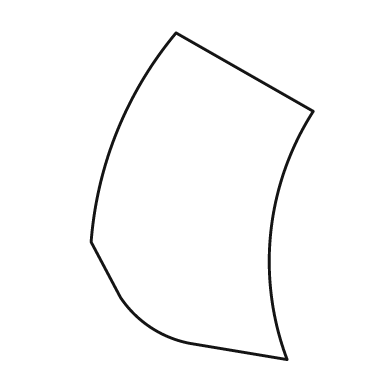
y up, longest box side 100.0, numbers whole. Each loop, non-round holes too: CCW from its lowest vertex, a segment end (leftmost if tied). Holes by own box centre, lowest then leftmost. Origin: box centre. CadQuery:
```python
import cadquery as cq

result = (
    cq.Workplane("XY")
    .moveTo(26.0, -50.0)
    .threePointArc((21.0, -11.0), (34.0, 26.0))
    .lineTo(-8.0, 50.0)
    .threePointArc((-26.0, 20.0), (-34.0, -14.0))
    .lineTo(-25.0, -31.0)
    .threePointArc((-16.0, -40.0), (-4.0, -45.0))
    .close()
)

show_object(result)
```